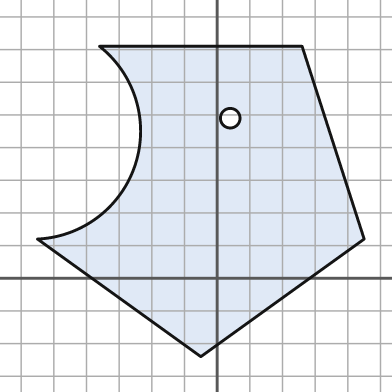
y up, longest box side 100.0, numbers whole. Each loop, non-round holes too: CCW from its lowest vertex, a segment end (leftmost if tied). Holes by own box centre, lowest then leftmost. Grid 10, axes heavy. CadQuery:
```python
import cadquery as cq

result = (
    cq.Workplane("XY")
    .moveTo(-5.0, -24.0)
    .lineTo(45.0, 12.0)
    .lineTo(26.0, 71.0)
    .lineTo(-36.0, 71.0)
    .threePointArc((-25.0, 35.0), (-55.0, 12.0))
    .close()
    .moveTo(4.0, 49.0)
    .circle(3.0)
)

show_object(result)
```